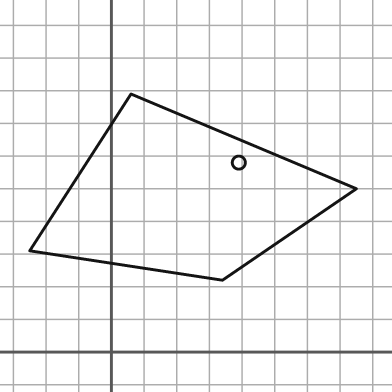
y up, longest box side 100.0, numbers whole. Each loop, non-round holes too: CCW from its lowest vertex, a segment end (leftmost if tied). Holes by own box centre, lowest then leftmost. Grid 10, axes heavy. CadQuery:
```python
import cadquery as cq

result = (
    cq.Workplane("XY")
    .moveTo(34.0, 22.0)
    .lineTo(75.0, 50.0)
    .lineTo(6.0, 79.0)
    .lineTo(-25.0, 31.0)
    .close()
    .moveTo(39.0, 58.0)
    .circle(2.0)
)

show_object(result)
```